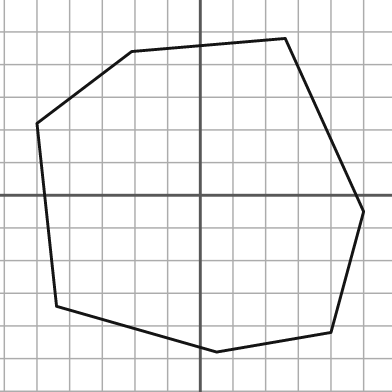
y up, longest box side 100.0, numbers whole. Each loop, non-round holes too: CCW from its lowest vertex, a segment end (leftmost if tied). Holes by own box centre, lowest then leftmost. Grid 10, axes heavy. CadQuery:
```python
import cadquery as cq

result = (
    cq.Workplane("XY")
    .moveTo(5.0, -48.0)
    .lineTo(40.0, -42.0)
    .lineTo(50.0, -5.0)
    .lineTo(26.0, 48.0)
    .lineTo(-21.0, 44.0)
    .lineTo(-50.0, 22.0)
    .lineTo(-44.0, -34.0)
    .close()
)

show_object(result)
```